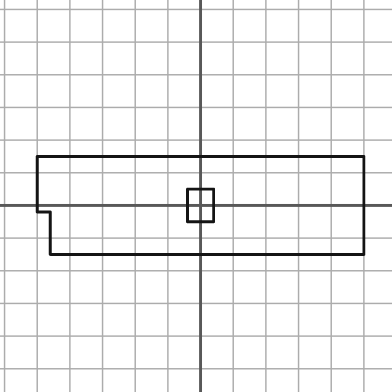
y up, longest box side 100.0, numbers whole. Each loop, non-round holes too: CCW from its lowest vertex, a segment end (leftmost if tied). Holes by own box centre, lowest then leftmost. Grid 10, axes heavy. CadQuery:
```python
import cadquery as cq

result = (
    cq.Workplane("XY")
    .moveTo(-46.0, -15.0)
    .lineTo(50.0, -15.0)
    .lineTo(50.0, 15.0)
    .lineTo(-50.0, 15.0)
    .lineTo(-50.0, -2.0)
    .lineTo(-46.0, -2.0)
    .close()
    .moveTo(-4.0, -5.0)
    .lineTo(4.0, -5.0)
    .lineTo(4.0, 5.0)
    .lineTo(-4.0, 5.0)
    .close()
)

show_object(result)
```